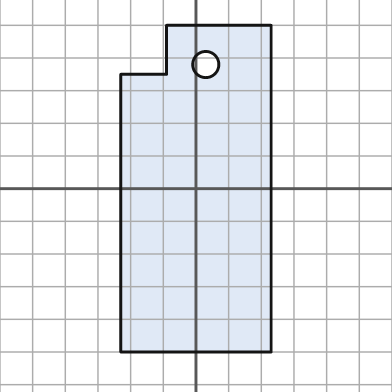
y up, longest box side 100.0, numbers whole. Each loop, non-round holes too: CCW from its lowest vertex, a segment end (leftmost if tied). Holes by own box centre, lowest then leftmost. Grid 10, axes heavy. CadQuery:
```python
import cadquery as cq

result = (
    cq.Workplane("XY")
    .moveTo(-23.0, -50.0)
    .lineTo(23.0, -50.0)
    .lineTo(23.0, 50.0)
    .lineTo(-9.0, 50.0)
    .lineTo(-9.0, 35.0)
    .lineTo(-23.0, 35.0)
    .close()
    .moveTo(3.0, 38.0)
    .circle(4.0)
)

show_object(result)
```